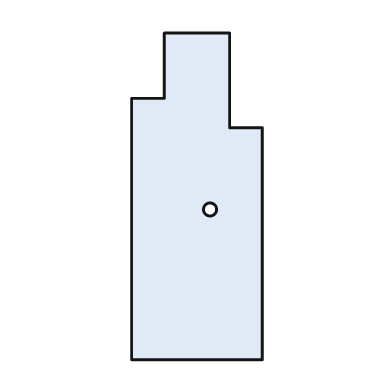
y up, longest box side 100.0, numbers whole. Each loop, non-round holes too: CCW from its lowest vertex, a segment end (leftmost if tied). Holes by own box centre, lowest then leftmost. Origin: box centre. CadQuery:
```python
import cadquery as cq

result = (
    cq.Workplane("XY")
    .moveTo(-20.0, -50.0)
    .lineTo(20.0, -50.0)
    .lineTo(20.0, 21.0)
    .lineTo(10.0, 21.0)
    .lineTo(10.0, 50.0)
    .lineTo(-10.0, 50.0)
    .lineTo(-10.0, 30.0)
    .lineTo(-20.0, 30.0)
    .close()
    .moveTo(4.0, -4.0)
    .circle(2.0)
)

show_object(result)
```